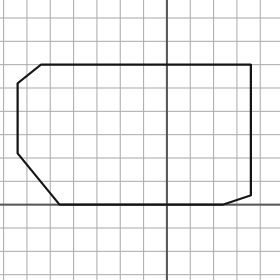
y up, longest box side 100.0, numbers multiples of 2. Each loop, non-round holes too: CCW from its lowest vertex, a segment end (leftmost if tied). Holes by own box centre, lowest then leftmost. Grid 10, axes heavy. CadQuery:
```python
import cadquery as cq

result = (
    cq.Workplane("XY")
    .moveTo(-46.0, 0.0)
    .lineTo(24.0, 0.0)
    .lineTo(36.0, 4.0)
    .lineTo(36.0, 60.0)
    .lineTo(-54.0, 60.0)
    .lineTo(-64.0, 52.0)
    .lineTo(-64.0, 22.0)
    .close()
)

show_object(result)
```